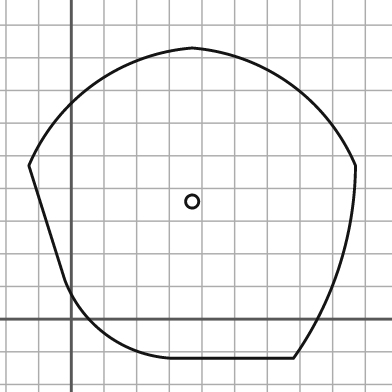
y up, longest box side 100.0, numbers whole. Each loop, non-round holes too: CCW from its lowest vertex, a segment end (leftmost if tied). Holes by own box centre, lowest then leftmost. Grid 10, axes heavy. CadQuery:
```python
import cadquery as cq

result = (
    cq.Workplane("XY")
    .moveTo(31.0, -12.0)
    .lineTo(68.0, -12.0)
    .threePointArc((82.0, 16.0), (87.0, 47.0))
    .threePointArc((67.0, 72.0), (37.0, 83.0))
    .threePointArc((7.0, 72.0), (-13.0, 47.0))
    .lineTo(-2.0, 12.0)
    .threePointArc((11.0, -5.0), (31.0, -12.0))
    .close()
    .moveTo(37.0, 36.0)
    .circle(2.0)
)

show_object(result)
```